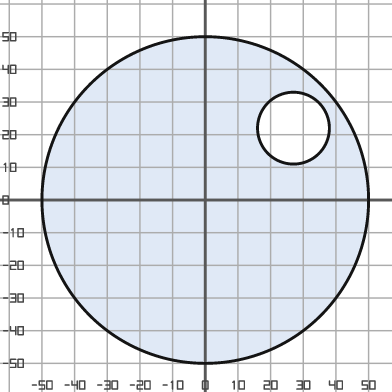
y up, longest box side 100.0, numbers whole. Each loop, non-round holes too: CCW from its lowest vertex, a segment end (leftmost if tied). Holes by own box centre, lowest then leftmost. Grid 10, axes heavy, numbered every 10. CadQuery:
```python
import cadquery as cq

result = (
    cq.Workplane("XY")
    .moveTo(0.0, 0.0)
    .circle(50.0)
    .moveTo(27.0, 22.0)
    .circle(11.0)
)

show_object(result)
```